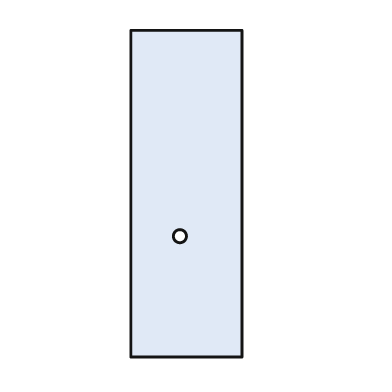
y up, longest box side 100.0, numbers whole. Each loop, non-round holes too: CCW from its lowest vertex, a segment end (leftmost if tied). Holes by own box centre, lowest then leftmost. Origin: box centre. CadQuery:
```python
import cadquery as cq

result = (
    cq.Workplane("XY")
    .moveTo(-17.0, -50.0)
    .lineTo(17.0, -50.0)
    .lineTo(17.0, 50.0)
    .lineTo(-17.0, 50.0)
    .close()
    .moveTo(-2.0, -13.0)
    .circle(2.0)
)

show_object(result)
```